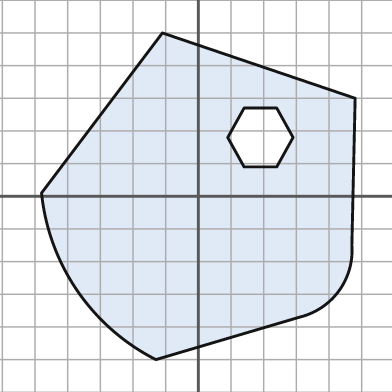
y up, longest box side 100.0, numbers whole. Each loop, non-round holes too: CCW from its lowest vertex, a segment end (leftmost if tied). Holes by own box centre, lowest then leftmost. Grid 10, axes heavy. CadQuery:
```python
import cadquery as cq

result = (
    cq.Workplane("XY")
    .moveTo(-13.0, -50.0)
    .lineTo(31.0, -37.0)
    .threePointArc((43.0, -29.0), (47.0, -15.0))
    .lineTo(48.0, 30.0)
    .lineTo(-11.0, 50.0)
    .lineTo(-48.0, 1.0)
    .threePointArc((-37.0, -29.0), (-13.0, -50.0))
    .close()
    .moveTo(14.0, 9.0)
    .lineTo(24.0, 9.0)
    .lineTo(29.0, 18.0)
    .lineTo(24.0, 27.0)
    .lineTo(14.0, 27.0)
    .lineTo(9.0, 18.0)
    .close()
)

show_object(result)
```